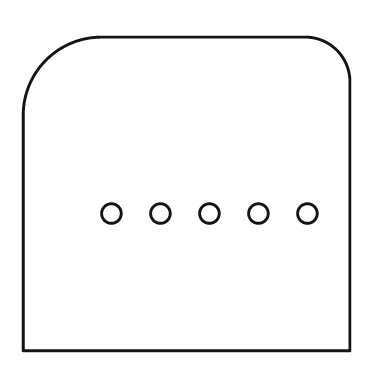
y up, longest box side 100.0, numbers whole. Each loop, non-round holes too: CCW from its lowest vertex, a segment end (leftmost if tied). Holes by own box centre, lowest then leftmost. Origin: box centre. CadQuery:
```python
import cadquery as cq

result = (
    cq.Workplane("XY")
    .moveTo(-50.0, -48.0)
    .lineTo(50.0, -48.0)
    .lineTo(50.0, 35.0)
    .threePointArc((46.0, 44.0), (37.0, 48.0))
    .lineTo(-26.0, 48.0)
    .threePointArc((-43.0, 41.0), (-50.0, 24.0))
    .close()
    .moveTo(-23.0, -6.0)
    .circle(3.0)
    .moveTo(-8.0, -6.0)
    .circle(3.0)
    .moveTo(7.0, -6.0)
    .circle(3.0)
    .moveTo(22.0, -6.0)
    .circle(3.0)
    .moveTo(37.0, -6.0)
    .circle(3.0)
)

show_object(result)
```